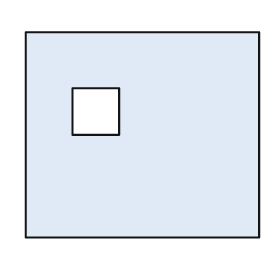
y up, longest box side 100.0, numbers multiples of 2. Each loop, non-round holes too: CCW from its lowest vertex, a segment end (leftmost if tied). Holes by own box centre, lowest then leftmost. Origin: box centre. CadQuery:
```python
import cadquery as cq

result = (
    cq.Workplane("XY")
    .moveTo(-50.0, -44.0)
    .lineTo(50.0, -44.0)
    .lineTo(50.0, 44.0)
    .lineTo(-50.0, 44.0)
    .close()
    .moveTo(-30.0, 0.0)
    .lineTo(-10.0, 0.0)
    .lineTo(-10.0, 20.0)
    .lineTo(-30.0, 20.0)
    .close()
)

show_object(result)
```